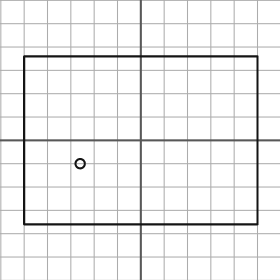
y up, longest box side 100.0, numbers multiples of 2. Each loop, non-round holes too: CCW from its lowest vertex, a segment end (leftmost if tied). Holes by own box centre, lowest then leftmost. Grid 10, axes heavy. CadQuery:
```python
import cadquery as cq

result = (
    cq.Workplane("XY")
    .moveTo(-50.0, -36.0)
    .lineTo(50.0, -36.0)
    .lineTo(50.0, 36.0)
    .lineTo(-50.0, 36.0)
    .close()
    .moveTo(-26.0, -10.0)
    .circle(2.0)
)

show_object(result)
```